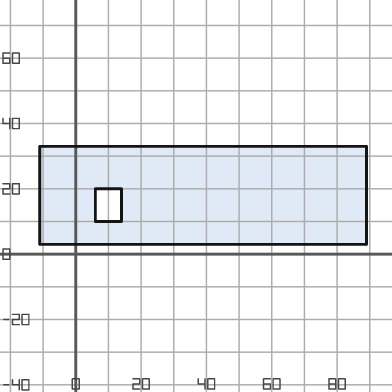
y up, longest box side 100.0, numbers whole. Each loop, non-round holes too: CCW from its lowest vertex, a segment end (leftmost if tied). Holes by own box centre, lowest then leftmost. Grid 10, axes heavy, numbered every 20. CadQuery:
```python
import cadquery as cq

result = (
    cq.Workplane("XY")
    .moveTo(-11.0, 3.0)
    .lineTo(89.0, 3.0)
    .lineTo(89.0, 33.0)
    .lineTo(-11.0, 33.0)
    .close()
    .moveTo(6.0, 10.0)
    .lineTo(14.0, 10.0)
    .lineTo(14.0, 20.0)
    .lineTo(6.0, 20.0)
    .close()
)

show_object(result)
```